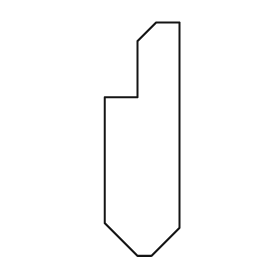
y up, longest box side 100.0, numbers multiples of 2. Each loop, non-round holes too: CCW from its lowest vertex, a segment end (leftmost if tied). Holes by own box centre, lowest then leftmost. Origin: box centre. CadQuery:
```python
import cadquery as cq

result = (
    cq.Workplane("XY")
    .moveTo(-2.0, -50.0)
    .lineTo(4.0, -50.0)
    .lineTo(16.0, -38.0)
    .lineTo(16.0, 50.0)
    .lineTo(6.0, 50.0)
    .lineTo(-2.0, 42.0)
    .lineTo(-2.0, 18.0)
    .lineTo(-16.0, 18.0)
    .lineTo(-16.0, -36.0)
    .close()
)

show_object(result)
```